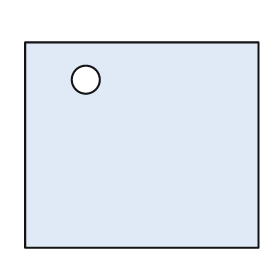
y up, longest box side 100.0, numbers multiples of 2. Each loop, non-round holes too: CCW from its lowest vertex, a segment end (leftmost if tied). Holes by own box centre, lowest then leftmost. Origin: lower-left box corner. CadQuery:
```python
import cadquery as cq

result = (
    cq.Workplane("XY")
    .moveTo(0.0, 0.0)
    .lineTo(100.0, 0.0)
    .lineTo(100.0, 88.0)
    .lineTo(0.0, 88.0)
    .close()
    .moveTo(26.0, 72.0)
    .circle(6.0)
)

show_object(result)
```